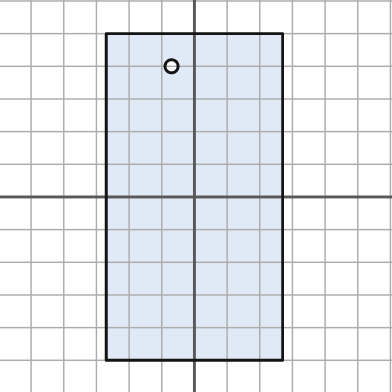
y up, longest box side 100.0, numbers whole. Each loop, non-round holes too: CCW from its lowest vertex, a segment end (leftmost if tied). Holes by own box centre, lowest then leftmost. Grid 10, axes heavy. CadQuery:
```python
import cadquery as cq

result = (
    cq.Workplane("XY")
    .moveTo(-27.0, -50.0)
    .lineTo(27.0, -50.0)
    .lineTo(27.0, 50.0)
    .lineTo(-27.0, 50.0)
    .close()
    .moveTo(-7.0, 40.0)
    .circle(2.0)
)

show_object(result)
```